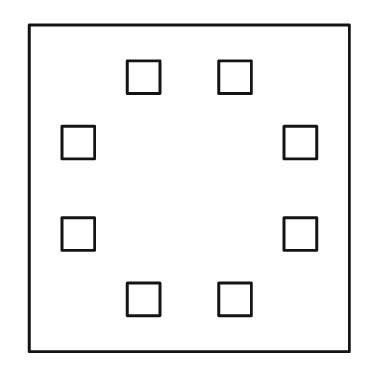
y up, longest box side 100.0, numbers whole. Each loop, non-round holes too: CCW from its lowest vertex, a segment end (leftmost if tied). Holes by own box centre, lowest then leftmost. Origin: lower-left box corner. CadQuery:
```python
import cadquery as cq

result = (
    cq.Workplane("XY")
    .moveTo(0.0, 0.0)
    .lineTo(98.0, 0.0)
    .lineTo(98.0, 100.0)
    .lineTo(0.0, 100.0)
    .close()
    .moveTo(30.0, 11.0)
    .lineTo(40.0, 11.0)
    .lineTo(40.0, 21.0)
    .lineTo(30.0, 21.0)
    .close()
    .moveTo(58.0, 11.0)
    .lineTo(68.0, 11.0)
    .lineTo(68.0, 21.0)
    .lineTo(58.0, 21.0)
    .close()
    .moveTo(10.0, 31.0)
    .lineTo(20.0, 31.0)
    .lineTo(20.0, 41.0)
    .lineTo(10.0, 41.0)
    .close()
    .moveTo(78.0, 31.0)
    .lineTo(88.0, 31.0)
    .lineTo(88.0, 41.0)
    .lineTo(78.0, 41.0)
    .close()
    .moveTo(10.0, 59.0)
    .lineTo(20.0, 59.0)
    .lineTo(20.0, 69.0)
    .lineTo(10.0, 69.0)
    .close()
    .moveTo(78.0, 59.0)
    .lineTo(88.0, 59.0)
    .lineTo(88.0, 69.0)
    .lineTo(78.0, 69.0)
    .close()
    .moveTo(30.0, 79.0)
    .lineTo(40.0, 79.0)
    .lineTo(40.0, 89.0)
    .lineTo(30.0, 89.0)
    .close()
    .moveTo(58.0, 79.0)
    .lineTo(68.0, 79.0)
    .lineTo(68.0, 89.0)
    .lineTo(58.0, 89.0)
    .close()
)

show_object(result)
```